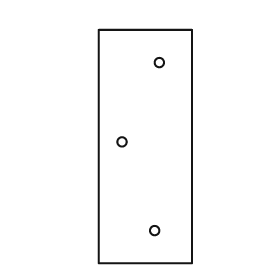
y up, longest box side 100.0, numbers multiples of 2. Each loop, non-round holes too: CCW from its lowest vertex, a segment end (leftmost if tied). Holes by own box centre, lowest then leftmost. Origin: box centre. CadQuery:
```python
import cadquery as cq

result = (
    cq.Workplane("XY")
    .moveTo(-20.0, -50.0)
    .lineTo(20.0, -50.0)
    .lineTo(20.0, 50.0)
    .lineTo(-20.0, 50.0)
    .close()
    .moveTo(4.0, -36.0)
    .circle(2.0)
    .moveTo(-10.0, 2.0)
    .circle(2.0)
    .moveTo(6.0, 36.0)
    .circle(2.0)
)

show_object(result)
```